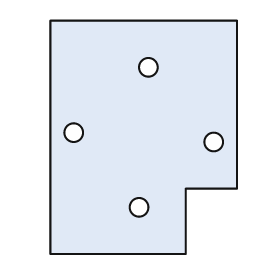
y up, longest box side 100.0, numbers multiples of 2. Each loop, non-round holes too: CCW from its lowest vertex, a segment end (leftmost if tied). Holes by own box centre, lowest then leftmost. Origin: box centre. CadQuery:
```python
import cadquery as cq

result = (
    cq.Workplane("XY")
    .moveTo(-40.0, -50.0)
    .lineTo(18.0, -50.0)
    .lineTo(18.0, -22.0)
    .lineTo(40.0, -22.0)
    .lineTo(40.0, 50.0)
    .lineTo(-40.0, 50.0)
    .close()
    .moveTo(-2.0, -30.0)
    .circle(4.0)
    .moveTo(30.0, -2.0)
    .circle(4.0)
    .moveTo(-30.0, 2.0)
    .circle(4.0)
    .moveTo(2.0, 30.0)
    .circle(4.0)
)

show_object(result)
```